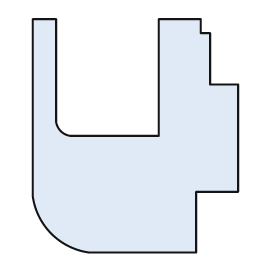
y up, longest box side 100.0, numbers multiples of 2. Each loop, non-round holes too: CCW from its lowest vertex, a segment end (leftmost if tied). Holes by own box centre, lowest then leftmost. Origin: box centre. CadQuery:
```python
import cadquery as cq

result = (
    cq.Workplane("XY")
    .moveTo(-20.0, -50.0)
    .lineTo(26.0, -50.0)
    .lineTo(26.0, -24.0)
    .lineTo(44.0, -24.0)
    .lineTo(44.0, 22.0)
    .lineTo(32.0, 22.0)
    .lineTo(32.0, 44.0)
    .lineTo(28.0, 44.0)
    .lineTo(28.0, 50.0)
    .lineTo(10.0, 50.0)
    .lineTo(10.0, 0.0)
    .lineTo(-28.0, 0.0)
    .threePointArc((-32.0, 2.0), (-34.0, 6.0))
    .lineTo(-34.0, 50.0)
    .lineTo(-44.0, 50.0)
    .lineTo(-44.0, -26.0)
    .threePointArc((-36.0, -42.0), (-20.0, -50.0))
    .close()
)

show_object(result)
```